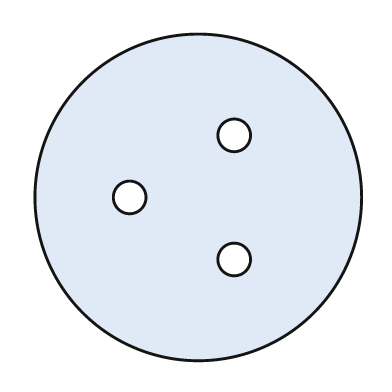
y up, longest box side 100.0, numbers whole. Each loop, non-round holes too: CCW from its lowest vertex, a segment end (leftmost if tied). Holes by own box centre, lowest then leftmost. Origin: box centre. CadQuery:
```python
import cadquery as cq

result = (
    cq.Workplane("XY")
    .moveTo(0.0, 0.0)
    .circle(50.0)
    .moveTo(11.0, -19.0)
    .circle(5.0)
    .moveTo(-21.0, 0.0)
    .circle(5.0)
    .moveTo(11.0, 19.0)
    .circle(5.0)
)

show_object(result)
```